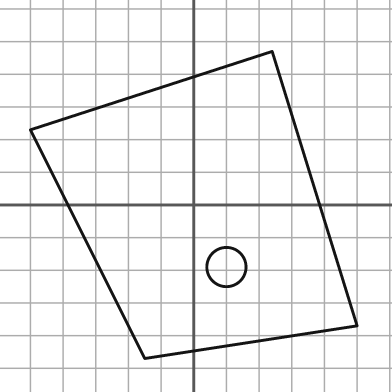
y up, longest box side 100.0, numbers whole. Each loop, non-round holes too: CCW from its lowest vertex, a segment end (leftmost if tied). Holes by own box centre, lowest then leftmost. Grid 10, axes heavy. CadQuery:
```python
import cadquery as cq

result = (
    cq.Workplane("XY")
    .moveTo(-15.0, -47.0)
    .lineTo(50.0, -37.0)
    .lineTo(24.0, 47.0)
    .lineTo(-50.0, 23.0)
    .close()
    .moveTo(10.0, -19.0)
    .circle(6.0)
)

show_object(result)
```